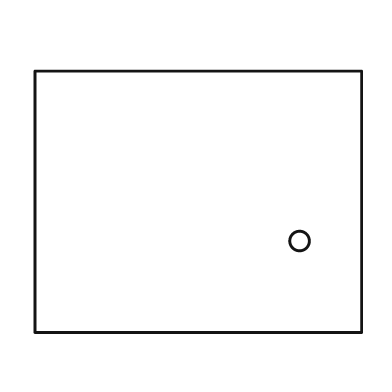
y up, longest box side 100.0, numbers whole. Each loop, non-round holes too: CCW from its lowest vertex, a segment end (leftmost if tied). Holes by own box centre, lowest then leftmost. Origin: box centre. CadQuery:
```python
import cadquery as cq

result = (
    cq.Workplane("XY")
    .moveTo(-50.0, -40.0)
    .lineTo(50.0, -40.0)
    .lineTo(50.0, 40.0)
    .lineTo(-50.0, 40.0)
    .close()
    .moveTo(31.0, -12.0)
    .circle(3.0)
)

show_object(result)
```